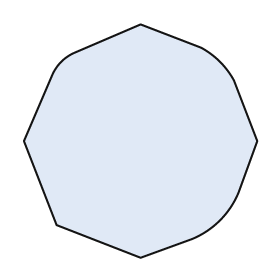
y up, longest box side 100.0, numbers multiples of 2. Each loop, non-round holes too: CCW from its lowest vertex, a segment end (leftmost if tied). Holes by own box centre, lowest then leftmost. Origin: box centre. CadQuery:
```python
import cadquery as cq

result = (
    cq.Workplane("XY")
    .moveTo(0.0, -50.0)
    .lineTo(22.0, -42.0)
    .threePointArc((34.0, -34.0), (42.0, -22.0))
    .lineTo(50.0, 0.0)
    .lineTo(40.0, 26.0)
    .threePointArc((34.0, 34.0), (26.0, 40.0))
    .lineTo(0.0, 50.0)
    .lineTo(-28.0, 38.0)
    .threePointArc((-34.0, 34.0), (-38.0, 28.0))
    .lineTo(-50.0, 0.0)
    .lineTo(-36.0, -36.0)
    .close()
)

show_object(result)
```